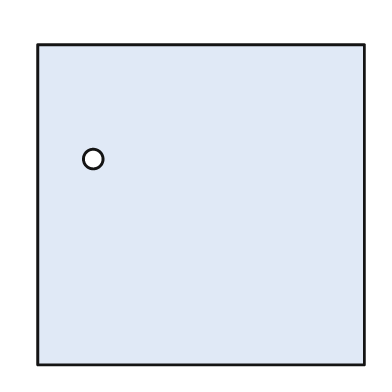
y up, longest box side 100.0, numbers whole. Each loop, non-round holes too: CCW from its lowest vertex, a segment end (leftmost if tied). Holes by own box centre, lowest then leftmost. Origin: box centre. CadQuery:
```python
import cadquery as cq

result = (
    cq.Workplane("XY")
    .moveTo(-50.0, -49.0)
    .lineTo(50.0, -49.0)
    .lineTo(50.0, 49.0)
    .lineTo(-50.0, 49.0)
    .close()
    .moveTo(-33.0, 14.0)
    .circle(3.0)
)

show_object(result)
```